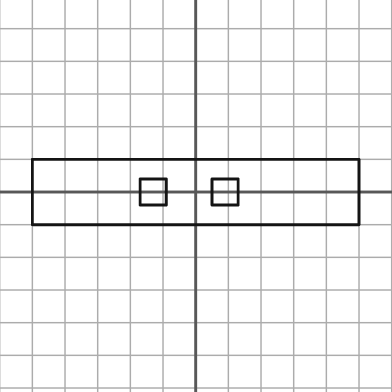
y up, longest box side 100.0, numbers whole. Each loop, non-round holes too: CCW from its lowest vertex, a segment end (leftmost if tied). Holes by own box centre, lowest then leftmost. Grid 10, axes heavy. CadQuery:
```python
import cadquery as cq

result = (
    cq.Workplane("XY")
    .moveTo(-50.0, -10.0)
    .lineTo(50.0, -10.0)
    .lineTo(50.0, 10.0)
    .lineTo(-50.0, 10.0)
    .close()
    .moveTo(-17.0, -4.0)
    .lineTo(-9.0, -4.0)
    .lineTo(-9.0, 4.0)
    .lineTo(-17.0, 4.0)
    .close()
    .moveTo(5.0, -4.0)
    .lineTo(13.0, -4.0)
    .lineTo(13.0, 4.0)
    .lineTo(5.0, 4.0)
    .close()
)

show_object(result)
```